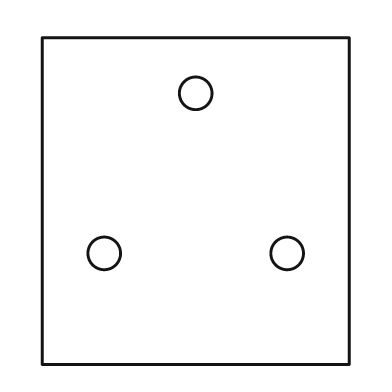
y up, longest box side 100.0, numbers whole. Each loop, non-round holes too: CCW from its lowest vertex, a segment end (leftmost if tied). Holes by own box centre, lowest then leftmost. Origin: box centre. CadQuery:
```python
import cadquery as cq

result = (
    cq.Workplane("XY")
    .moveTo(-47.0, -50.0)
    .lineTo(47.0, -50.0)
    .lineTo(47.0, 50.0)
    .lineTo(-47.0, 50.0)
    .close()
    .moveTo(-28.0, -16.0)
    .circle(5.0)
    .moveTo(28.0, -16.0)
    .circle(5.0)
    .moveTo(0.0, 33.0)
    .circle(5.0)
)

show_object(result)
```